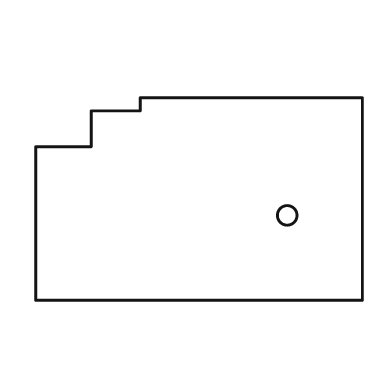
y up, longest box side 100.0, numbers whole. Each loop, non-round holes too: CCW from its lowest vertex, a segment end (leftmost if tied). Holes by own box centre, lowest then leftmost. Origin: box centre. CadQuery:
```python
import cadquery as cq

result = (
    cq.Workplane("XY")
    .moveTo(-50.0, -31.0)
    .lineTo(50.0, -31.0)
    .lineTo(50.0, 31.0)
    .lineTo(-18.0, 31.0)
    .lineTo(-18.0, 27.0)
    .lineTo(-33.0, 27.0)
    .lineTo(-33.0, 16.0)
    .lineTo(-50.0, 16.0)
    .close()
    .moveTo(27.0, -5.0)
    .circle(3.0)
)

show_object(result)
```